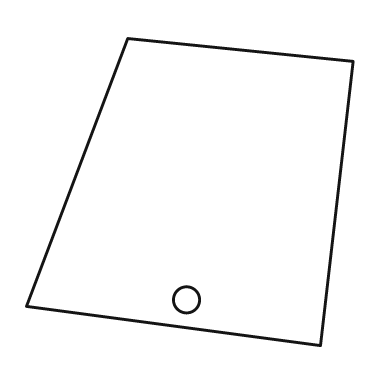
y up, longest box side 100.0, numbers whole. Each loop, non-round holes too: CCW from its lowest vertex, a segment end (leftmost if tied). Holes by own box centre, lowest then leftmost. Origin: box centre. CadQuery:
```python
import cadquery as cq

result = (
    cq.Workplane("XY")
    .moveTo(40.0, -47.0)
    .lineTo(50.0, 40.0)
    .lineTo(-19.0, 47.0)
    .lineTo(-50.0, -35.0)
    .close()
    .moveTo(-1.0, -33.0)
    .circle(4.0)
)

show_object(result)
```